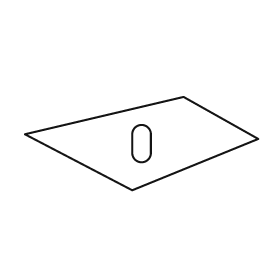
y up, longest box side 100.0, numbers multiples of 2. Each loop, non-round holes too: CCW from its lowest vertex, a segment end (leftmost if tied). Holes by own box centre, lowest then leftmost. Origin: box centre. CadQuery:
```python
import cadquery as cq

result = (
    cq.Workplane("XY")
    .moveTo(-4.0, -20.0)
    .lineTo(50.0, 2.0)
    .lineTo(18.0, 20.0)
    .lineTo(-50.0, 4.0)
    .close()
    .moveTo(-4.0, -4.0)
    .threePointArc((0.0, -8.0), (4.0, -4.0))
    .lineTo(4.0, 4.0)
    .threePointArc((0.0, 8.0), (-4.0, 4.0))
    .close()
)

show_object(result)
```